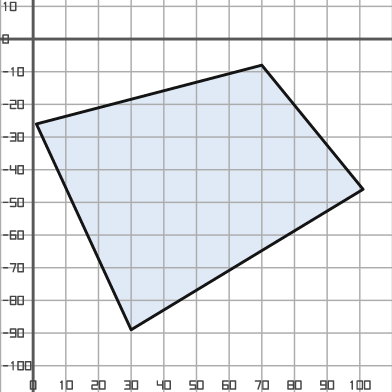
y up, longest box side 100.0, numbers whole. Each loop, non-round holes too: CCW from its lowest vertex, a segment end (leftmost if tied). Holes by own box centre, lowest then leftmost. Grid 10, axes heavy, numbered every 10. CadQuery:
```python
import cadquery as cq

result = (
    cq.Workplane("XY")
    .moveTo(30.0, -89.0)
    .lineTo(101.0, -46.0)
    .lineTo(70.0, -8.0)
    .lineTo(1.0, -26.0)
    .close()
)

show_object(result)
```